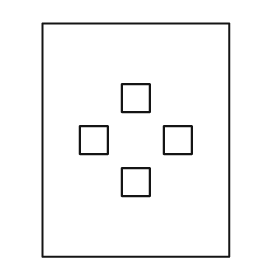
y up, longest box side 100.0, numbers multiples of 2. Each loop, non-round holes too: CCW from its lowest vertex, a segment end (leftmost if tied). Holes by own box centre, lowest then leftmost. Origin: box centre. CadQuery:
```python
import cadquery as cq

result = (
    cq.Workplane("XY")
    .moveTo(-40.0, -50.0)
    .lineTo(40.0, -50.0)
    .lineTo(40.0, 50.0)
    .lineTo(-40.0, 50.0)
    .close()
    .moveTo(-6.0, -24.0)
    .lineTo(6.0, -24.0)
    .lineTo(6.0, -12.0)
    .lineTo(-6.0, -12.0)
    .close()
    .moveTo(-24.0, -6.0)
    .lineTo(-12.0, -6.0)
    .lineTo(-12.0, 6.0)
    .lineTo(-24.0, 6.0)
    .close()
    .moveTo(12.0, -6.0)
    .lineTo(24.0, -6.0)
    .lineTo(24.0, 6.0)
    .lineTo(12.0, 6.0)
    .close()
    .moveTo(-6.0, 12.0)
    .lineTo(6.0, 12.0)
    .lineTo(6.0, 24.0)
    .lineTo(-6.0, 24.0)
    .close()
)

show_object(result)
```